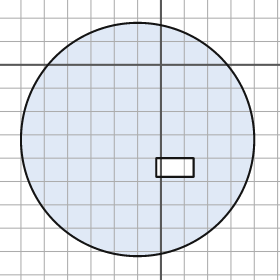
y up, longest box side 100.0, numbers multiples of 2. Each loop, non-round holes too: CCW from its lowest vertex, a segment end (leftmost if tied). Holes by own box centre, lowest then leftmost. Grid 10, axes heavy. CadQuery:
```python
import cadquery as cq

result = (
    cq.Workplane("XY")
    .moveTo(-10.0, -32.0)
    .circle(50.0)
    .moveTo(-2.0, -48.0)
    .lineTo(14.0, -48.0)
    .lineTo(14.0, -40.0)
    .lineTo(-2.0, -40.0)
    .close()
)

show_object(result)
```